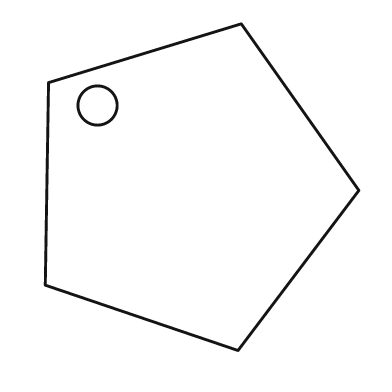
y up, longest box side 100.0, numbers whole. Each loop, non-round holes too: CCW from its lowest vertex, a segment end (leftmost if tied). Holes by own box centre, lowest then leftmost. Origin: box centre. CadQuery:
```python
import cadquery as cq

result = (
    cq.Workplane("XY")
    .moveTo(11.0, -50.0)
    .lineTo(48.0, -1.0)
    .lineTo(12.0, 50.0)
    .lineTo(-47.0, 32.0)
    .lineTo(-48.0, -30.0)
    .close()
    .moveTo(-32.0, 25.0)
    .circle(6.0)
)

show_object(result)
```